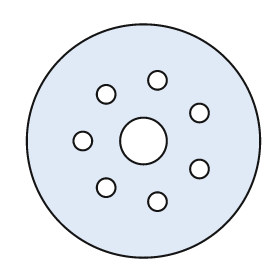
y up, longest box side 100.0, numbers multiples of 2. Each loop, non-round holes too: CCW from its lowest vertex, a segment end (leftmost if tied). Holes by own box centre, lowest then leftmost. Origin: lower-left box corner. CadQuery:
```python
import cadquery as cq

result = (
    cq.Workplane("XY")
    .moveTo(50.0, 50.0)
    .circle(50.0)
    .moveTo(56.0, 24.0)
    .circle(4.0)
    .moveTo(34.0, 30.0)
    .circle(4.0)
    .moveTo(74.0, 38.0)
    .circle(4.0)
    .moveTo(24.0, 50.0)
    .circle(4.0)
    .moveTo(50.0, 50.0)
    .circle(10.0)
    .moveTo(74.0, 62.0)
    .circle(4.0)
    .moveTo(34.0, 70.0)
    .circle(4.0)
    .moveTo(56.0, 76.0)
    .circle(4.0)
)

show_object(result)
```